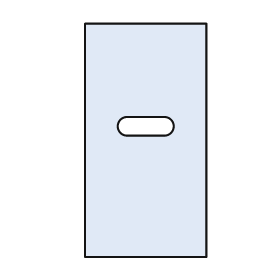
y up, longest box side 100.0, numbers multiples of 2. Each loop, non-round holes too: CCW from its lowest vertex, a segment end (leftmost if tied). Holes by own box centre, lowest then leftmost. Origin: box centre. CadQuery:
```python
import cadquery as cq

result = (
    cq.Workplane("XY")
    .moveTo(-26.0, -50.0)
    .lineTo(26.0, -50.0)
    .lineTo(26.0, 50.0)
    .lineTo(-26.0, 50.0)
    .close()
    .moveTo(-8.0, 2.0)
    .lineTo(8.0, 2.0)
    .threePointArc((12.0, 6.0), (8.0, 10.0))
    .lineTo(-8.0, 10.0)
    .threePointArc((-12.0, 6.0), (-8.0, 2.0))
    .close()
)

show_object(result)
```